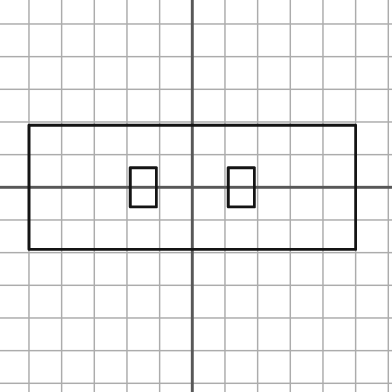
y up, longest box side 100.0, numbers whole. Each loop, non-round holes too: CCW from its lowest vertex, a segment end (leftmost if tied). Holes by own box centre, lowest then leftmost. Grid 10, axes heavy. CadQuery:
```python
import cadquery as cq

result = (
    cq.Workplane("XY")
    .moveTo(-50.0, -19.0)
    .lineTo(50.0, -19.0)
    .lineTo(50.0, 19.0)
    .lineTo(-50.0, 19.0)
    .close()
    .moveTo(-19.0, -6.0)
    .lineTo(-11.0, -6.0)
    .lineTo(-11.0, 6.0)
    .lineTo(-19.0, 6.0)
    .close()
    .moveTo(11.0, -6.0)
    .lineTo(19.0, -6.0)
    .lineTo(19.0, 6.0)
    .lineTo(11.0, 6.0)
    .close()
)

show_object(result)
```